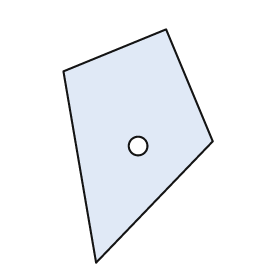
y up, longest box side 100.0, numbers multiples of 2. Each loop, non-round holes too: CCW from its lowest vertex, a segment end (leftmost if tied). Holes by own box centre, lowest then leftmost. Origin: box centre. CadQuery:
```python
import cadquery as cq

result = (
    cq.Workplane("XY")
    .moveTo(-18.0, -50.0)
    .lineTo(32.0, 2.0)
    .lineTo(12.0, 50.0)
    .lineTo(-32.0, 32.0)
    .close()
    .moveTo(0.0, 0.0)
    .circle(4.0)
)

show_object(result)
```